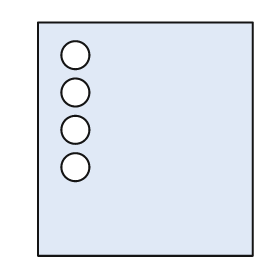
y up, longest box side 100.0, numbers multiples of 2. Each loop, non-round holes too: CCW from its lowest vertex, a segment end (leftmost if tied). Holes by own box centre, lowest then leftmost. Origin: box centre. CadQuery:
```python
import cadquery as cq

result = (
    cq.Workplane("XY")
    .moveTo(-46.0, -50.0)
    .lineTo(46.0, -50.0)
    .lineTo(46.0, 50.0)
    .lineTo(-46.0, 50.0)
    .close()
    .moveTo(-30.0, -12.0)
    .circle(6.0)
    .moveTo(-30.0, 4.0)
    .circle(6.0)
    .moveTo(-30.0, 20.0)
    .circle(6.0)
    .moveTo(-30.0, 36.0)
    .circle(6.0)
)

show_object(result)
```